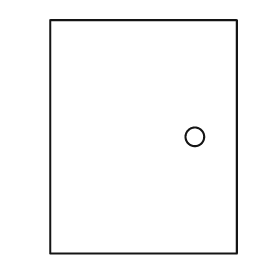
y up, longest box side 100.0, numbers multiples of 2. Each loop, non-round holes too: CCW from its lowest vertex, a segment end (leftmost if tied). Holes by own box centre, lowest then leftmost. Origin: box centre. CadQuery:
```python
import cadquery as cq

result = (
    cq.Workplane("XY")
    .moveTo(-40.0, -50.0)
    .lineTo(40.0, -50.0)
    .lineTo(40.0, 50.0)
    .lineTo(-40.0, 50.0)
    .close()
    .moveTo(22.0, 0.0)
    .circle(4.0)
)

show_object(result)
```